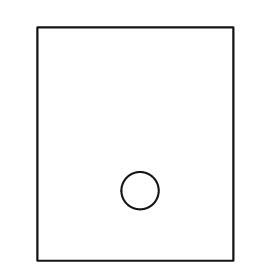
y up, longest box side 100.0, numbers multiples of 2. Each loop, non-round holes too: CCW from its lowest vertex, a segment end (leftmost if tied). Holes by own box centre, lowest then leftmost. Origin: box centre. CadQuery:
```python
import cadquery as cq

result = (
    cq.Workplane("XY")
    .moveTo(-42.0, -50.0)
    .lineTo(42.0, -50.0)
    .lineTo(42.0, 50.0)
    .lineTo(-42.0, 50.0)
    .close()
    .moveTo(2.0, -20.0)
    .circle(8.0)
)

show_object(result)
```